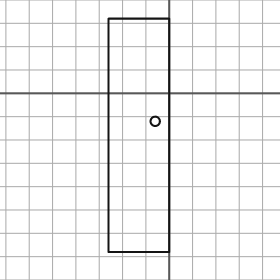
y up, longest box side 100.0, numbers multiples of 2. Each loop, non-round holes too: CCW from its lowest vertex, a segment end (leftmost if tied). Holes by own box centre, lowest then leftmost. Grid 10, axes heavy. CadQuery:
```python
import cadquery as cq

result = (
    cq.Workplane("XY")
    .moveTo(-26.0, -68.0)
    .lineTo(0.0, -68.0)
    .lineTo(0.0, 32.0)
    .lineTo(-26.0, 32.0)
    .close()
    .moveTo(-6.0, -12.0)
    .circle(2.0)
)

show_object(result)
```